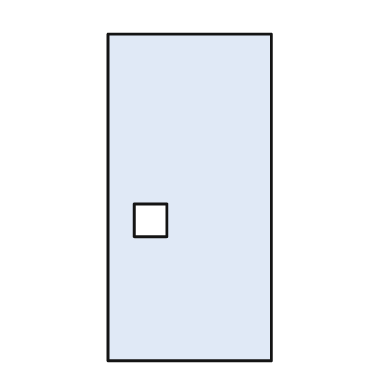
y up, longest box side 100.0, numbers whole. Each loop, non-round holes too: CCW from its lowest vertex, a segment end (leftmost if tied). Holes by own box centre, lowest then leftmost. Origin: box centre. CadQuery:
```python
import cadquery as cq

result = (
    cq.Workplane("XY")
    .moveTo(-25.0, -50.0)
    .lineTo(25.0, -50.0)
    .lineTo(25.0, 50.0)
    .lineTo(-25.0, 50.0)
    .close()
    .moveTo(-17.0, -12.0)
    .lineTo(-7.0, -12.0)
    .lineTo(-7.0, -2.0)
    .lineTo(-17.0, -2.0)
    .close()
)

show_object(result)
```